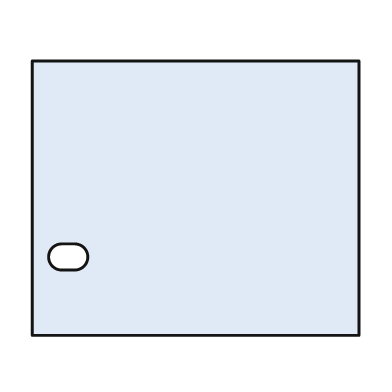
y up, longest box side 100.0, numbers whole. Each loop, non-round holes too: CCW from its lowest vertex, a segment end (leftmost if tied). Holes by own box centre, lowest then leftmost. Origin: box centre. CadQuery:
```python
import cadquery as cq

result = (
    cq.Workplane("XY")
    .moveTo(-50.0, -42.0)
    .lineTo(50.0, -42.0)
    .lineTo(50.0, 42.0)
    .lineTo(-50.0, 42.0)
    .close()
    .moveTo(-41.0, -22.0)
    .lineTo(-37.0, -22.0)
    .threePointArc((-33.0, -18.0), (-37.0, -14.0))
    .lineTo(-41.0, -14.0)
    .threePointArc((-45.0, -18.0), (-41.0, -22.0))
    .close()
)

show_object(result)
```